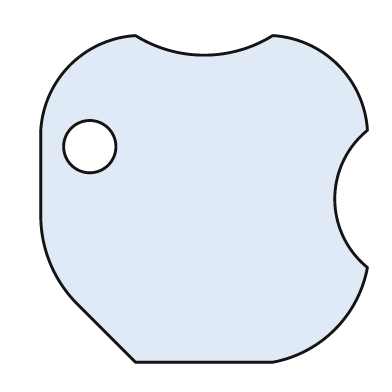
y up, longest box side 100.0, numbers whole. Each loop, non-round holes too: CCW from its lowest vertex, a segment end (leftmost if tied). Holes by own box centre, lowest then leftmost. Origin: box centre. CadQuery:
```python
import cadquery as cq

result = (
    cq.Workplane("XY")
    .moveTo(-21.0, -50.0)
    .lineTo(21.0, -50.0)
    .threePointArc((40.0, -40.0), (50.0, -21.0))
    .threePointArc((40.0, 0.0), (50.0, 21.0))
    .threePointArc((41.0, 41.0), (21.0, 50.0))
    .threePointArc((0.0, 44.0), (-21.0, 50.0))
    .threePointArc((-41.0, 41.0), (-50.0, 21.0))
    .lineTo(-50.0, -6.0)
    .threePointArc((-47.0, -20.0), (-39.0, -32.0))
    .close()
    .moveTo(-35.0, 16.0)
    .circle(8.0)
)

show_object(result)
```